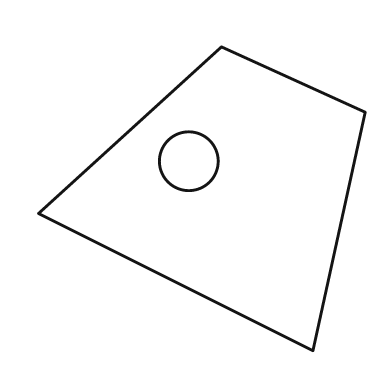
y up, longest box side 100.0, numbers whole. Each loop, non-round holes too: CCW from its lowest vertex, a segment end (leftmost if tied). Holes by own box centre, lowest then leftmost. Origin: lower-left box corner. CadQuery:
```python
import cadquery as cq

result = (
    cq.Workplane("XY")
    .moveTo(84.0, 0.0)
    .lineTo(100.0, 73.0)
    .lineTo(56.0, 93.0)
    .lineTo(0.0, 42.0)
    .close()
    .moveTo(46.0, 58.0)
    .circle(9.0)
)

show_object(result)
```